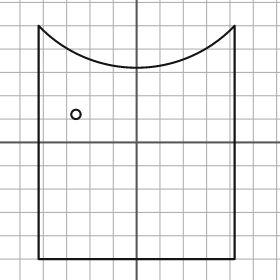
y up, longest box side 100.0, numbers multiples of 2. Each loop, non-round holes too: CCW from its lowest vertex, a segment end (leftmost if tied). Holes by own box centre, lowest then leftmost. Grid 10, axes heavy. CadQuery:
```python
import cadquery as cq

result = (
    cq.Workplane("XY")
    .moveTo(-42.0, -50.0)
    .lineTo(42.0, -50.0)
    .lineTo(42.0, 50.0)
    .threePointArc((0.0, 32.0), (-42.0, 50.0))
    .close()
    .moveTo(-26.0, 12.0)
    .circle(2.0)
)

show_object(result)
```